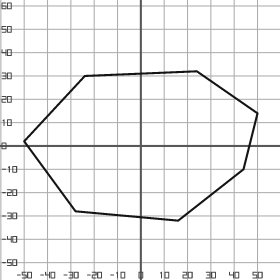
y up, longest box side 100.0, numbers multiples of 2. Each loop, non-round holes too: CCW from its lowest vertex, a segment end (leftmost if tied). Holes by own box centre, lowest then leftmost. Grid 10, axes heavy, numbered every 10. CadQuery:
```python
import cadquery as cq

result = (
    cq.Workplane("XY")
    .moveTo(16.0, -32.0)
    .lineTo(44.0, -10.0)
    .lineTo(50.0, 14.0)
    .lineTo(24.0, 32.0)
    .lineTo(-24.0, 30.0)
    .lineTo(-50.0, 2.0)
    .lineTo(-28.0, -28.0)
    .close()
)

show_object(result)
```